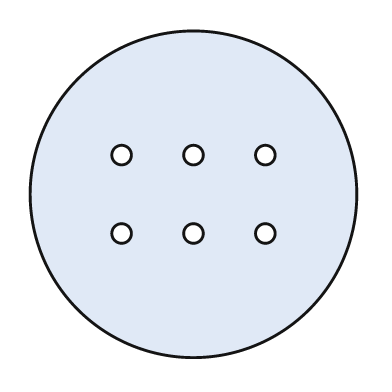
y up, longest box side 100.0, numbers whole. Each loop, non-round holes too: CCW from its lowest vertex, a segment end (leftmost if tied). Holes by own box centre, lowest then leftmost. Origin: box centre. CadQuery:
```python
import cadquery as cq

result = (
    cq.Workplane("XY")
    .moveTo(0.0, 0.0)
    .circle(50.0)
    .moveTo(-22.0, -12.0)
    .circle(3.0)
    .moveTo(0.0, -12.0)
    .circle(3.0)
    .moveTo(22.0, -12.0)
    .circle(3.0)
    .moveTo(-22.0, 12.0)
    .circle(3.0)
    .moveTo(0.0, 12.0)
    .circle(3.0)
    .moveTo(22.0, 12.0)
    .circle(3.0)
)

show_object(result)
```